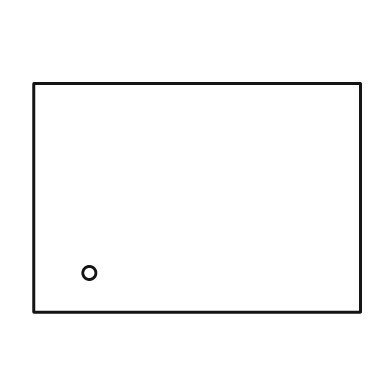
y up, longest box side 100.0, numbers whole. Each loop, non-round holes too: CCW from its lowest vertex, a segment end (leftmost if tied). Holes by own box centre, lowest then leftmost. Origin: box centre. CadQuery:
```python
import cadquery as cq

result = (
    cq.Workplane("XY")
    .moveTo(-50.0, -35.0)
    .lineTo(50.0, -35.0)
    .lineTo(50.0, 35.0)
    .lineTo(-50.0, 35.0)
    .close()
    .moveTo(-33.0, -23.0)
    .circle(2.0)
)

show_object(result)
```